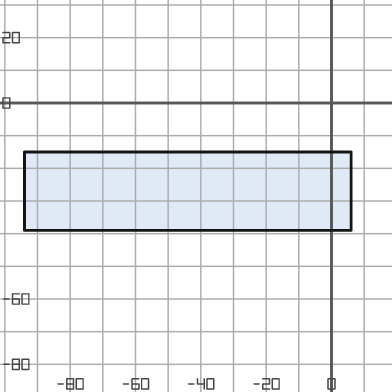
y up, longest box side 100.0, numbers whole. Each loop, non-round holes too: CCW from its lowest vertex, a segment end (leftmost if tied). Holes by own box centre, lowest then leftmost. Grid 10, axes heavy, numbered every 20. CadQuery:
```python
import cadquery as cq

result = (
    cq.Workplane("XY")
    .moveTo(-94.0, -39.0)
    .lineTo(6.0, -39.0)
    .lineTo(6.0, -15.0)
    .lineTo(-94.0, -15.0)
    .close()
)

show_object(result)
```